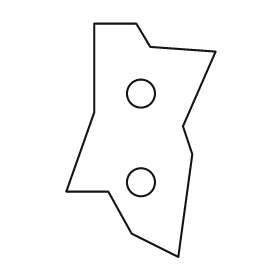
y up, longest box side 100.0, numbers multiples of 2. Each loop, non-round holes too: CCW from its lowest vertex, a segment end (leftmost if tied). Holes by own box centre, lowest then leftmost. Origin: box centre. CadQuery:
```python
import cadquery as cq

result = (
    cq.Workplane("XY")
    .moveTo(16.0, -50.0)
    .lineTo(22.0, -6.0)
    .lineTo(18.0, 6.0)
    .lineTo(32.0, 38.0)
    .lineTo(4.0, 40.0)
    .lineTo(-2.0, 50.0)
    .lineTo(-20.0, 50.0)
    .lineTo(-20.0, 12.0)
    .lineTo(-32.0, -22.0)
    .lineTo(-14.0, -22.0)
    .lineTo(-4.0, -40.0)
    .close()
    .moveTo(0.0, -18.0)
    .circle(6.0)
    .moveTo(0.0, 20.0)
    .circle(6.0)
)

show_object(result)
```